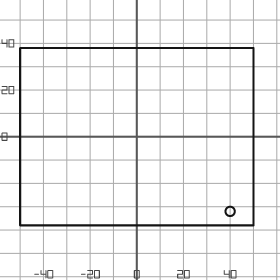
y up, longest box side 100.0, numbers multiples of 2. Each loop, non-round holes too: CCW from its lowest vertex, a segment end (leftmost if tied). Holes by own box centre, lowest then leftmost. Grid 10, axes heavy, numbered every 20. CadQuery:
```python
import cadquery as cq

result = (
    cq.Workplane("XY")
    .moveTo(-50.0, -38.0)
    .lineTo(50.0, -38.0)
    .lineTo(50.0, 38.0)
    .lineTo(-50.0, 38.0)
    .close()
    .moveTo(40.0, -32.0)
    .circle(2.0)
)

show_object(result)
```